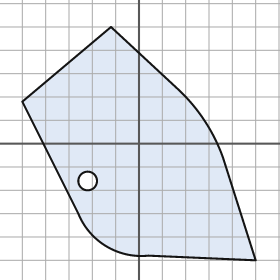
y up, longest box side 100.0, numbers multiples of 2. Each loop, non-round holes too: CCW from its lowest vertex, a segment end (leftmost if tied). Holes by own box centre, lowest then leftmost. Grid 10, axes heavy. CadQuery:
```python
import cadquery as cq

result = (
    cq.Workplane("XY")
    .moveTo(50.0, -50.0)
    .lineTo(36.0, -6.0)
    .threePointArc((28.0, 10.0), (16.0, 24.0))
    .lineTo(-12.0, 50.0)
    .lineTo(-50.0, 18.0)
    .lineTo(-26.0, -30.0)
    .threePointArc((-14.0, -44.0), (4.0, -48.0))
    .close()
    .moveTo(-22.0, -16.0)
    .circle(4.0)
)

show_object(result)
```